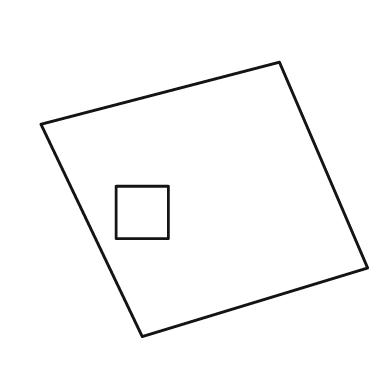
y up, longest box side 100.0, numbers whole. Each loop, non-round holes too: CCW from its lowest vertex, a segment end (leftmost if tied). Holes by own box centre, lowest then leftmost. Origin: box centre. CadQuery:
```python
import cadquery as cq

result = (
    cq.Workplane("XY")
    .moveTo(-19.0, -42.0)
    .lineTo(50.0, -21.0)
    .lineTo(23.0, 42.0)
    .lineTo(-50.0, 23.0)
    .close()
    .moveTo(-27.0, -12.0)
    .lineTo(-11.0, -12.0)
    .lineTo(-11.0, 4.0)
    .lineTo(-27.0, 4.0)
    .close()
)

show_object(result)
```